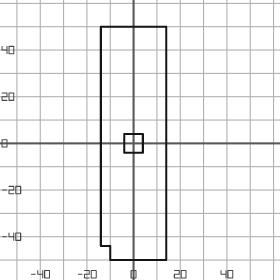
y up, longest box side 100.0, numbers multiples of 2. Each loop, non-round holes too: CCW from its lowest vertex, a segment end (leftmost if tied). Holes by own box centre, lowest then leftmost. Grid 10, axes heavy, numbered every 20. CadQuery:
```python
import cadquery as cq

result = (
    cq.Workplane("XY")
    .moveTo(-10.0, -50.0)
    .lineTo(14.0, -50.0)
    .lineTo(14.0, 50.0)
    .lineTo(-14.0, 50.0)
    .lineTo(-14.0, -44.0)
    .lineTo(-10.0, -44.0)
    .close()
    .moveTo(-4.0, -4.0)
    .lineTo(4.0, -4.0)
    .lineTo(4.0, 4.0)
    .lineTo(-4.0, 4.0)
    .close()
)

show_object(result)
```